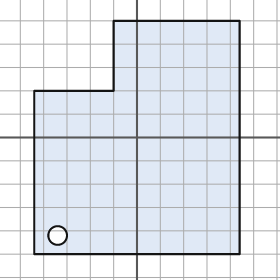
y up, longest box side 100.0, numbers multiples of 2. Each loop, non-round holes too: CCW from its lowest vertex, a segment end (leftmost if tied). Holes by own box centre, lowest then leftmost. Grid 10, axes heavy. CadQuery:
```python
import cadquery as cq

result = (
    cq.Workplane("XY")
    .moveTo(-44.0, -50.0)
    .lineTo(44.0, -50.0)
    .lineTo(44.0, 50.0)
    .lineTo(-10.0, 50.0)
    .lineTo(-10.0, 20.0)
    .lineTo(-44.0, 20.0)
    .close()
    .moveTo(-34.0, -42.0)
    .circle(4.0)
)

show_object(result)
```